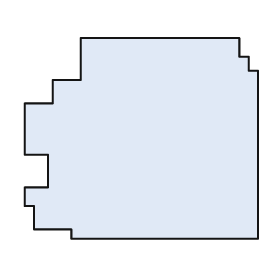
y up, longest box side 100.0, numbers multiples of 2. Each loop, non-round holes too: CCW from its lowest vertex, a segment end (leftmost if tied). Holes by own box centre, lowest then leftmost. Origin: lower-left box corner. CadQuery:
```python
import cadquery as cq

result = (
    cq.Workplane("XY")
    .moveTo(20.0, 0.0)
    .lineTo(100.0, 0.0)
    .lineTo(100.0, 72.0)
    .lineTo(96.0, 72.0)
    .lineTo(96.0, 78.0)
    .lineTo(92.0, 78.0)
    .lineTo(92.0, 86.0)
    .lineTo(24.0, 86.0)
    .lineTo(24.0, 68.0)
    .lineTo(12.0, 68.0)
    .lineTo(12.0, 58.0)
    .lineTo(0.0, 58.0)
    .lineTo(0.0, 36.0)
    .lineTo(10.0, 36.0)
    .lineTo(10.0, 22.0)
    .lineTo(0.0, 22.0)
    .lineTo(0.0, 14.0)
    .lineTo(4.0, 14.0)
    .lineTo(4.0, 4.0)
    .lineTo(20.0, 4.0)
    .close()
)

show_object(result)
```